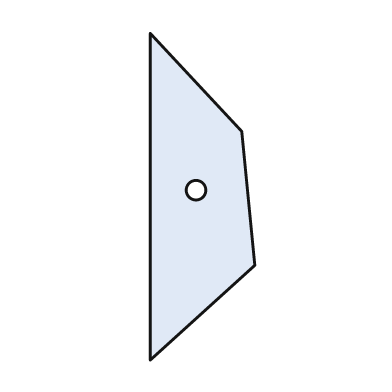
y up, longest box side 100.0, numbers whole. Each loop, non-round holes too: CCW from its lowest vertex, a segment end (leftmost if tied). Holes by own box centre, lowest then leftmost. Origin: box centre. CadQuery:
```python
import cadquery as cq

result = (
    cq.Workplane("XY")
    .moveTo(-16.0, -50.0)
    .lineTo(16.0, -21.0)
    .lineTo(12.0, 20.0)
    .lineTo(-16.0, 50.0)
    .close()
    .moveTo(-2.0, 2.0)
    .circle(3.0)
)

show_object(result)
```